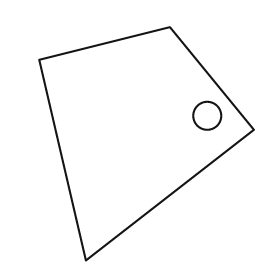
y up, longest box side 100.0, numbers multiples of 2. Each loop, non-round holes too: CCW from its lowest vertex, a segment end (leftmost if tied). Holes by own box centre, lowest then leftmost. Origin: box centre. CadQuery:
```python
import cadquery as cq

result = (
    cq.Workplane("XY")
    .moveTo(-26.0, -50.0)
    .lineTo(46.0, 6.0)
    .lineTo(10.0, 50.0)
    .lineTo(-46.0, 36.0)
    .close()
    .moveTo(26.0, 12.0)
    .circle(6.0)
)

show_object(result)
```